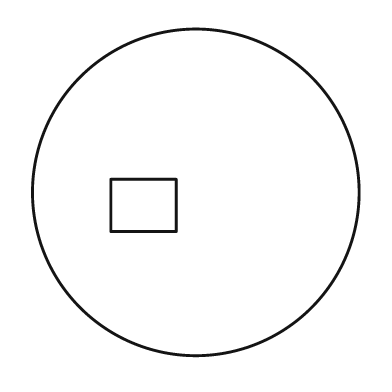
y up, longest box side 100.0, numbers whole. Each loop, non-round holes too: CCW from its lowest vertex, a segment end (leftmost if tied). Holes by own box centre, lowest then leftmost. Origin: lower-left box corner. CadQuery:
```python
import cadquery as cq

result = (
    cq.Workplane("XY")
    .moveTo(50.0, 50.0)
    .circle(50.0)
    .moveTo(24.0, 38.0)
    .lineTo(44.0, 38.0)
    .lineTo(44.0, 54.0)
    .lineTo(24.0, 54.0)
    .close()
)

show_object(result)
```